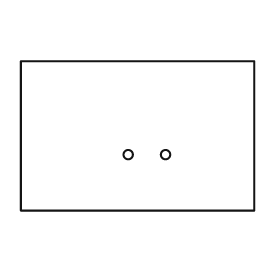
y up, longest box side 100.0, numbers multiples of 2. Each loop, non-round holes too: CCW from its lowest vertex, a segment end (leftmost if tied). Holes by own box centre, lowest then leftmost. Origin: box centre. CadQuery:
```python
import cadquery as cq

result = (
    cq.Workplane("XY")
    .moveTo(-50.0, -32.0)
    .lineTo(50.0, -32.0)
    .lineTo(50.0, 32.0)
    .lineTo(-50.0, 32.0)
    .close()
    .moveTo(-4.0, -8.0)
    .circle(2.0)
    .moveTo(12.0, -8.0)
    .circle(2.0)
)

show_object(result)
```